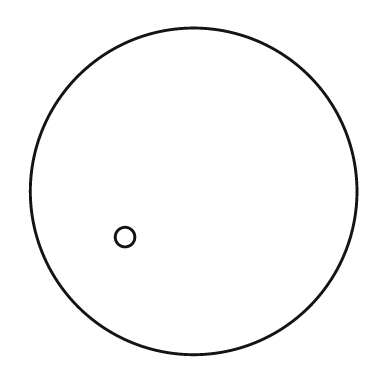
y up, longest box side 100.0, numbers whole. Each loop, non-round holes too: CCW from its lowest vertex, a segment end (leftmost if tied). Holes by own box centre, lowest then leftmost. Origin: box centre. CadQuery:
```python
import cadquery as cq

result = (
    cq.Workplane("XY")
    .moveTo(0.0, 0.0)
    .circle(50.0)
    .moveTo(-21.0, -14.0)
    .circle(3.0)
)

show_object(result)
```